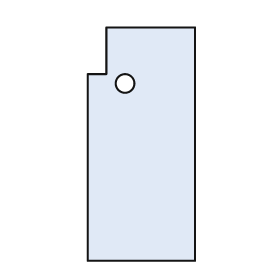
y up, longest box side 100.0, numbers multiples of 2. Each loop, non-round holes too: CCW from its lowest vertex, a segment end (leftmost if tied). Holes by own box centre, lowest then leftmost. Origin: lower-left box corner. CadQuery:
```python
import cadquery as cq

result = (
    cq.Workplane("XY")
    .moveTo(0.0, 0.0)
    .lineTo(46.0, 0.0)
    .lineTo(46.0, 100.0)
    .lineTo(8.0, 100.0)
    .lineTo(8.0, 80.0)
    .lineTo(0.0, 80.0)
    .close()
    .moveTo(16.0, 76.0)
    .circle(4.0)
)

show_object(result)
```